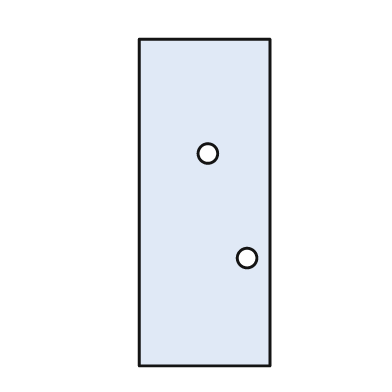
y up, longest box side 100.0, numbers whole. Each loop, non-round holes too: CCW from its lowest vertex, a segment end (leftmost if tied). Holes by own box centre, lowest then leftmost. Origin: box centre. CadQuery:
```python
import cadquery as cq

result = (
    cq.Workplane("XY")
    .moveTo(-20.0, -50.0)
    .lineTo(20.0, -50.0)
    .lineTo(20.0, 50.0)
    .lineTo(-20.0, 50.0)
    .close()
    .moveTo(13.0, -17.0)
    .circle(3.0)
    .moveTo(1.0, 15.0)
    .circle(3.0)
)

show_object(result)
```